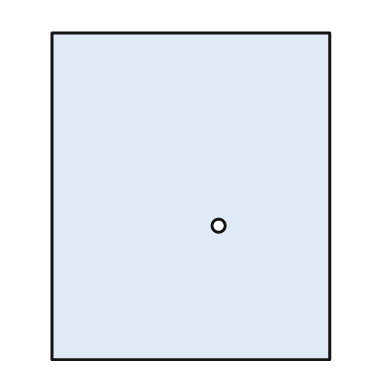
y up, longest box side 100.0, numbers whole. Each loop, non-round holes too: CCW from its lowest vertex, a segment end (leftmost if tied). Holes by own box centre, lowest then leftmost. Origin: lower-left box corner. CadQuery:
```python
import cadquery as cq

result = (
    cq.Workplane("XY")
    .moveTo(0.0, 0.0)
    .lineTo(85.0, 0.0)
    .lineTo(85.0, 100.0)
    .lineTo(0.0, 100.0)
    .close()
    .moveTo(51.0, 41.0)
    .circle(2.0)
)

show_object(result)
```